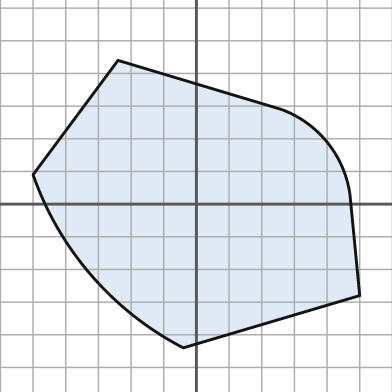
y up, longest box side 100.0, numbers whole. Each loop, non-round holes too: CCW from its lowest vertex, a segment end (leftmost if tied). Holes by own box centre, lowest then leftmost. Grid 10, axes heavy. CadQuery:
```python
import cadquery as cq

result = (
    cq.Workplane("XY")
    .moveTo(-4.0, -44.0)
    .lineTo(50.0, -28.0)
    .lineTo(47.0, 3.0)
    .threePointArc((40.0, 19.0), (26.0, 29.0))
    .lineTo(-24.0, 44.0)
    .lineTo(-50.0, 9.0)
    .threePointArc((-32.0, -22.0), (-4.0, -44.0))
    .close()
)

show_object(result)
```